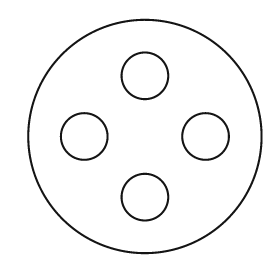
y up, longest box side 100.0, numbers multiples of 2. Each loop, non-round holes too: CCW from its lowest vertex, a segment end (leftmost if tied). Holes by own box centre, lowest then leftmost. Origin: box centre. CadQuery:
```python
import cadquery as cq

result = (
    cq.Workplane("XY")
    .moveTo(0.0, 0.0)
    .circle(50.0)
    .moveTo(0.0, -26.0)
    .circle(10.0)
    .moveTo(-26.0, 0.0)
    .circle(10.0)
    .moveTo(26.0, 0.0)
    .circle(10.0)
    .moveTo(0.0, 26.0)
    .circle(10.0)
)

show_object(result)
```